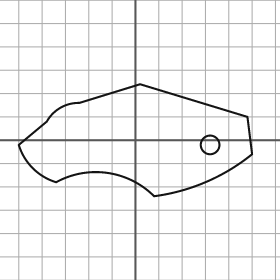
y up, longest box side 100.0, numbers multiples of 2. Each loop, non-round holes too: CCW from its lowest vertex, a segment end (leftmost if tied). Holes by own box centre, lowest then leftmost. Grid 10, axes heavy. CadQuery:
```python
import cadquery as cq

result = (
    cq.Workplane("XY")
    .moveTo(8.0, -24.0)
    .threePointArc((30.0, -18.0), (50.0, -6.0))
    .lineTo(48.0, 10.0)
    .lineTo(2.0, 24.0)
    .lineTo(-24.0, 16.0)
    .threePointArc((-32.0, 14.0), (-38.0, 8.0))
    .lineTo(-50.0, -2.0)
    .threePointArc((-44.0, -12.0), (-34.0, -18.0))
    .threePointArc((-12.0, -14.0), (8.0, -24.0))
    .close()
    .moveTo(32.0, -2.0)
    .circle(4.0)
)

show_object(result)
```